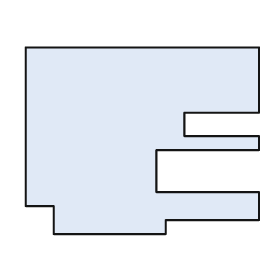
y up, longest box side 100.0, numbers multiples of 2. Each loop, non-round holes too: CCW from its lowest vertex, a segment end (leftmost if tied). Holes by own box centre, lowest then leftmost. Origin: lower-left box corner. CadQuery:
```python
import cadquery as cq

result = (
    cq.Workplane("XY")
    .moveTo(12.0, 0.0)
    .lineTo(60.0, 0.0)
    .lineTo(60.0, 6.0)
    .lineTo(100.0, 6.0)
    .lineTo(100.0, 18.0)
    .lineTo(56.0, 18.0)
    .lineTo(56.0, 36.0)
    .lineTo(100.0, 36.0)
    .lineTo(100.0, 42.0)
    .lineTo(68.0, 42.0)
    .lineTo(68.0, 52.0)
    .lineTo(100.0, 52.0)
    .lineTo(100.0, 80.0)
    .lineTo(0.0, 80.0)
    .lineTo(0.0, 12.0)
    .lineTo(12.0, 12.0)
    .close()
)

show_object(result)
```